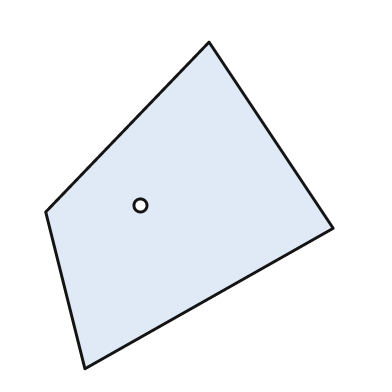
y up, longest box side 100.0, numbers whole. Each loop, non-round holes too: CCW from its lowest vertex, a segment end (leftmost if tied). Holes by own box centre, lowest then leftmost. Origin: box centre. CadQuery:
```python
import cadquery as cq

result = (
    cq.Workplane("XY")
    .moveTo(-32.0, -50.0)
    .lineTo(44.0, -7.0)
    .lineTo(6.0, 50.0)
    .lineTo(-44.0, -2.0)
    .close()
    .moveTo(-15.0, 0.0)
    .circle(2.0)
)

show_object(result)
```